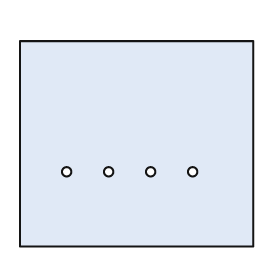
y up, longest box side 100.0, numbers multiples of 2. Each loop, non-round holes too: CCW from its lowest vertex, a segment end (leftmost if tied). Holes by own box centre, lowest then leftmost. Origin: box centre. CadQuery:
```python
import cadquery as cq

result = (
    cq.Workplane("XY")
    .moveTo(-50.0, -44.0)
    .lineTo(50.0, -44.0)
    .lineTo(50.0, 44.0)
    .lineTo(-50.0, 44.0)
    .close()
    .moveTo(-30.0, -12.0)
    .circle(2.0)
    .moveTo(-12.0, -12.0)
    .circle(2.0)
    .moveTo(6.0, -12.0)
    .circle(2.0)
    .moveTo(24.0, -12.0)
    .circle(2.0)
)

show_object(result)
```